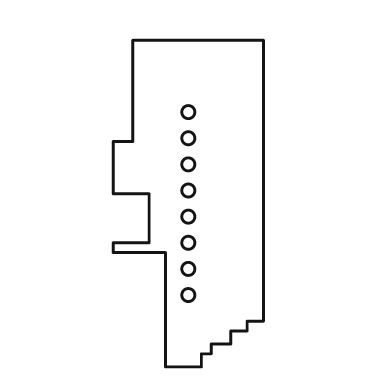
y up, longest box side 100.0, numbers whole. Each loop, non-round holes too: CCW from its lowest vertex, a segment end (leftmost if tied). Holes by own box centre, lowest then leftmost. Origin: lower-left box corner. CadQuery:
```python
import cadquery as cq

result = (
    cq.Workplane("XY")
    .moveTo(16.0, 0.0)
    .lineTo(27.0, 0.0)
    .lineTo(27.0, 4.0)
    .lineTo(30.0, 4.0)
    .lineTo(30.0, 7.0)
    .lineTo(36.0, 7.0)
    .lineTo(36.0, 11.0)
    .lineTo(41.0, 11.0)
    .lineTo(41.0, 14.0)
    .lineTo(46.0, 14.0)
    .lineTo(46.0, 100.0)
    .lineTo(6.0, 100.0)
    .lineTo(6.0, 69.0)
    .lineTo(0.0, 69.0)
    .lineTo(0.0, 53.0)
    .lineTo(11.0, 53.0)
    .lineTo(11.0, 38.0)
    .lineTo(0.0, 38.0)
    .lineTo(0.0, 35.0)
    .lineTo(16.0, 35.0)
    .close()
    .moveTo(23.0, 22.0)
    .circle(2.0)
    .moveTo(23.0, 30.0)
    .circle(2.0)
    .moveTo(23.0, 38.0)
    .circle(2.0)
    .moveTo(23.0, 46.0)
    .circle(2.0)
    .moveTo(23.0, 54.0)
    .circle(2.0)
    .moveTo(23.0, 62.0)
    .circle(2.0)
    .moveTo(23.0, 70.0)
    .circle(2.0)
    .moveTo(23.0, 78.0)
    .circle(2.0)
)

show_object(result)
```